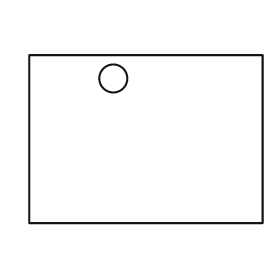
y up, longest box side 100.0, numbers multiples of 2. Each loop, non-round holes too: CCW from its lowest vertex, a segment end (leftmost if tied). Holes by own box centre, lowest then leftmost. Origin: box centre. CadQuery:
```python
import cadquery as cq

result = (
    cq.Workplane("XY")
    .moveTo(-50.0, -36.0)
    .lineTo(50.0, -36.0)
    .lineTo(50.0, 36.0)
    .lineTo(-50.0, 36.0)
    .close()
    .moveTo(-14.0, 26.0)
    .circle(6.0)
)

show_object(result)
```